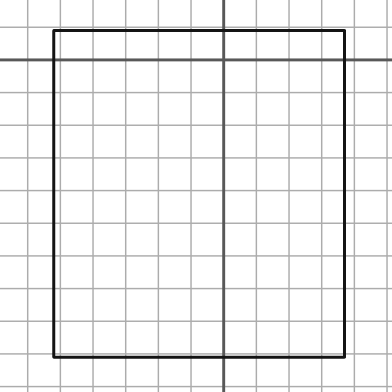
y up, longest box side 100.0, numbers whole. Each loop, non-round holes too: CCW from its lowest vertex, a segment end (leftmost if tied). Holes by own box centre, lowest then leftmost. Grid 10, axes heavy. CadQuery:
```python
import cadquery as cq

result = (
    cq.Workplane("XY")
    .moveTo(-52.0, -91.0)
    .lineTo(37.0, -91.0)
    .lineTo(37.0, 9.0)
    .lineTo(-52.0, 9.0)
    .close()
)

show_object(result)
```